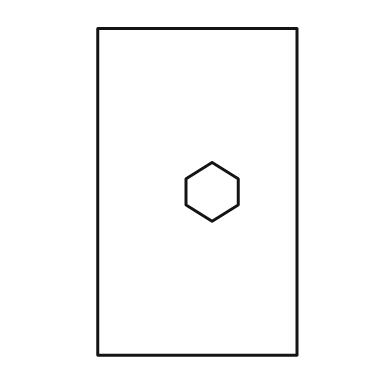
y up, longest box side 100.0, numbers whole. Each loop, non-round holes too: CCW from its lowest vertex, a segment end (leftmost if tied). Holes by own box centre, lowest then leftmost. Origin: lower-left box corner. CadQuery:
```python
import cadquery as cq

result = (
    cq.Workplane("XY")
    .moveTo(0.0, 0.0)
    .lineTo(61.0, 0.0)
    .lineTo(61.0, 100.0)
    .lineTo(0.0, 100.0)
    .close()
    .moveTo(35.0, 41.0)
    .lineTo(43.0, 46.0)
    .lineTo(43.0, 54.0)
    .lineTo(35.0, 59.0)
    .lineTo(27.0, 54.0)
    .lineTo(27.0, 46.0)
    .close()
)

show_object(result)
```